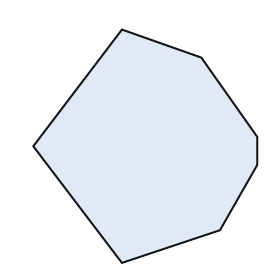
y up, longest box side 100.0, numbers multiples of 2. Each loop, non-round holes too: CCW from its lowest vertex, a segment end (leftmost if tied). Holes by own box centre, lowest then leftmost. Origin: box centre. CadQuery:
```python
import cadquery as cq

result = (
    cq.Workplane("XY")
    .moveTo(-10.0, -50.0)
    .lineTo(32.0, -36.0)
    .lineTo(48.0, -8.0)
    .lineTo(48.0, 4.0)
    .lineTo(24.0, 38.0)
    .lineTo(-10.0, 50.0)
    .lineTo(-48.0, 0.0)
    .close()
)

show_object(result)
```